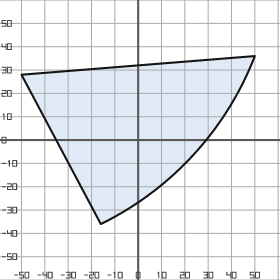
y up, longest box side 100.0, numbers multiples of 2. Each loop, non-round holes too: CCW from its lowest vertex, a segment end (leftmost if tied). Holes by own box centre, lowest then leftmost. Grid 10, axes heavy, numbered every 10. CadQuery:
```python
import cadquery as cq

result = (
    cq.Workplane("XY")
    .moveTo(-16.0, -36.0)
    .threePointArc((24.0, -6.0), (50.0, 36.0))
    .lineTo(-50.0, 28.0)
    .close()
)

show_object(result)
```